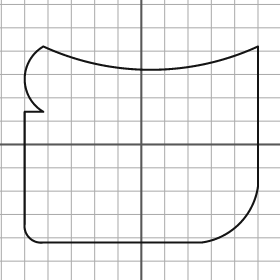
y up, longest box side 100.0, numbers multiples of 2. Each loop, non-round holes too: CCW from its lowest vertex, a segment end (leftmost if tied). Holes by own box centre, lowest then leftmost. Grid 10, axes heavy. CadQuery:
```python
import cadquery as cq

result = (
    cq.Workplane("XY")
    .moveTo(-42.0, -42.0)
    .lineTo(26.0, -42.0)
    .threePointArc((42.0, -34.0), (50.0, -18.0))
    .lineTo(50.0, 42.0)
    .threePointArc((4.0, 32.0), (-42.0, 42.0))
    .threePointArc((-50.0, 28.0), (-42.0, 14.0))
    .lineTo(-50.0, 14.0)
    .lineTo(-50.0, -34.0)
    .threePointArc((-48.0, -40.0), (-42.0, -42.0))
    .close()
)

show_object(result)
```